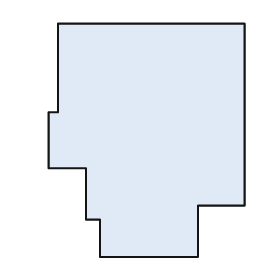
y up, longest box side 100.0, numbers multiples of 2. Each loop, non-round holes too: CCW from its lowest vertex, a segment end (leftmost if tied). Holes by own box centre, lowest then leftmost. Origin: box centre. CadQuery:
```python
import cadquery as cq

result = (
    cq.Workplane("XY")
    .moveTo(-20.0, -50.0)
    .lineTo(22.0, -50.0)
    .lineTo(22.0, -28.0)
    .lineTo(42.0, -28.0)
    .lineTo(42.0, 50.0)
    .lineTo(-38.0, 50.0)
    .lineTo(-38.0, 12.0)
    .lineTo(-42.0, 12.0)
    .lineTo(-42.0, -12.0)
    .lineTo(-26.0, -12.0)
    .lineTo(-26.0, -34.0)
    .lineTo(-20.0, -34.0)
    .close()
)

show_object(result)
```